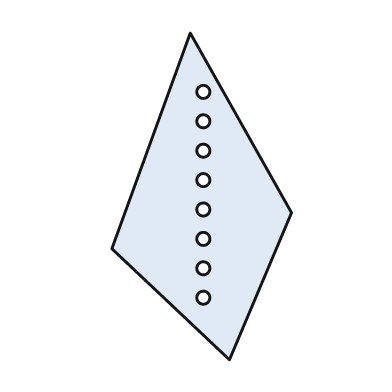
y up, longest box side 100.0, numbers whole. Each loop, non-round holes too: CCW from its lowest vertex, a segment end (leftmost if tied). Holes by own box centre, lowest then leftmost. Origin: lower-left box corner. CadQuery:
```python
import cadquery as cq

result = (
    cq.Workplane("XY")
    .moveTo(36.0, 0.0)
    .lineTo(55.0, 45.0)
    .lineTo(24.0, 100.0)
    .lineTo(0.0, 34.0)
    .close()
    .moveTo(28.0, 19.0)
    .circle(2.0)
    .moveTo(28.0, 28.0)
    .circle(2.0)
    .moveTo(28.0, 37.0)
    .circle(2.0)
    .moveTo(28.0, 46.0)
    .circle(2.0)
    .moveTo(28.0, 55.0)
    .circle(2.0)
    .moveTo(28.0, 64.0)
    .circle(2.0)
    .moveTo(28.0, 73.0)
    .circle(2.0)
    .moveTo(28.0, 82.0)
    .circle(2.0)
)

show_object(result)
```